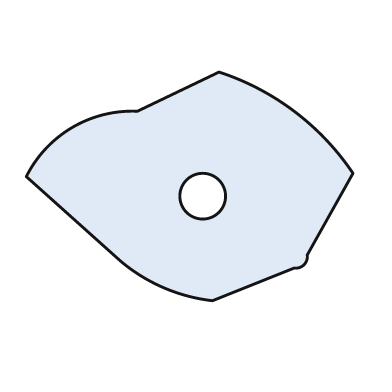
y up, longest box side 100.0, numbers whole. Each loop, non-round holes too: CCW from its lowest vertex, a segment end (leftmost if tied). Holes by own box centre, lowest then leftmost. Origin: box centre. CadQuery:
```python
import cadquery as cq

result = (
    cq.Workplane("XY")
    .moveTo(7.0, -35.0)
    .lineTo(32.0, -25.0)
    .threePointArc((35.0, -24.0), (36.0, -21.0))
    .lineTo(50.0, 4.0)
    .threePointArc((32.0, 23.0), (9.0, 35.0))
    .lineTo(-16.0, 23.0)
    .threePointArc((-36.0, 18.0), (-50.0, 3.0))
    .lineTo(-21.0, -23.0)
    .threePointArc((-8.0, -31.0), (7.0, -35.0))
    .close()
    .moveTo(4.0, -3.0)
    .circle(7.0)
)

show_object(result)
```